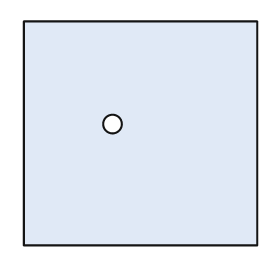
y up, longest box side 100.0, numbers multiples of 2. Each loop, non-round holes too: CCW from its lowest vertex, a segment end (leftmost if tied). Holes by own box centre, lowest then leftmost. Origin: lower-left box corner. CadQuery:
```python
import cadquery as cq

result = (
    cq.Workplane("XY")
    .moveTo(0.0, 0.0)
    .lineTo(100.0, 0.0)
    .lineTo(100.0, 96.0)
    .lineTo(0.0, 96.0)
    .close()
    .moveTo(38.0, 52.0)
    .circle(4.0)
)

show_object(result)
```